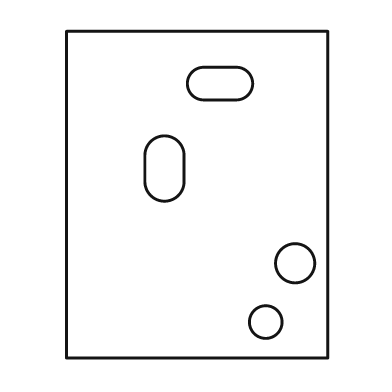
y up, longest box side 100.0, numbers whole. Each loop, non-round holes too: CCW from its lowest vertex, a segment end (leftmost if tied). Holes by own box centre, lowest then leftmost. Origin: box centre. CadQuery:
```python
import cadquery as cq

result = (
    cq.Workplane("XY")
    .moveTo(-40.0, -50.0)
    .lineTo(40.0, -50.0)
    .lineTo(40.0, 50.0)
    .lineTo(-40.0, 50.0)
    .close()
    .moveTo(21.0, -39.0)
    .circle(5.0)
    .moveTo(30.0, -21.0)
    .circle(6.0)
    .moveTo(-16.0, 4.0)
    .threePointArc((-10.0, -2.0), (-4.0, 4.0))
    .lineTo(-4.0, 12.0)
    .threePointArc((-10.0, 18.0), (-16.0, 12.0))
    .close()
    .moveTo(2.0, 29.0)
    .lineTo(12.0, 29.0)
    .threePointArc((17.0, 34.0), (12.0, 39.0))
    .lineTo(2.0, 39.0)
    .threePointArc((-3.0, 34.0), (2.0, 29.0))
    .close()
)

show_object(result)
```